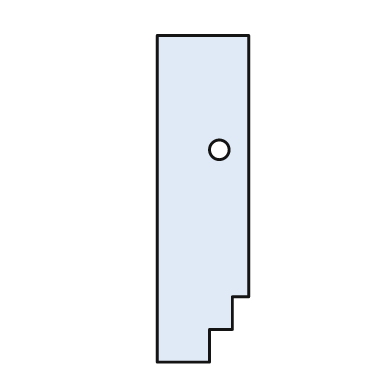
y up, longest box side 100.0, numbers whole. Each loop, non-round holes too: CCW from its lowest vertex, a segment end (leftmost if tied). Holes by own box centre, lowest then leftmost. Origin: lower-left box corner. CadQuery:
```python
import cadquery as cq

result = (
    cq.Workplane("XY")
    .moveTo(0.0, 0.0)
    .lineTo(16.0, 0.0)
    .lineTo(16.0, 10.0)
    .lineTo(23.0, 10.0)
    .lineTo(23.0, 20.0)
    .lineTo(28.0, 20.0)
    .lineTo(28.0, 100.0)
    .lineTo(0.0, 100.0)
    .close()
    .moveTo(19.0, 65.0)
    .circle(3.0)
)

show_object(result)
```